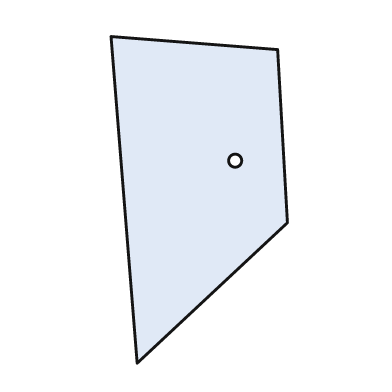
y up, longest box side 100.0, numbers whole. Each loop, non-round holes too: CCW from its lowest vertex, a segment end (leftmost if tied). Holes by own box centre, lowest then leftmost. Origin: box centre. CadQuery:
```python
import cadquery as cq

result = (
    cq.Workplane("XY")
    .moveTo(-19.0, -50.0)
    .lineTo(27.0, -7.0)
    .lineTo(24.0, 46.0)
    .lineTo(-27.0, 50.0)
    .close()
    .moveTo(11.0, 12.0)
    .circle(2.0)
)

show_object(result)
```